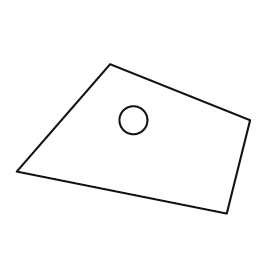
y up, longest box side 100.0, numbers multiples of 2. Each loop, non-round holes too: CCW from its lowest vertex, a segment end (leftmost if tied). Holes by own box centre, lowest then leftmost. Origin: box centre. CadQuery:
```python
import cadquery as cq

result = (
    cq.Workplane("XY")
    .moveTo(40.0, -32.0)
    .lineTo(50.0, 8.0)
    .lineTo(-10.0, 32.0)
    .lineTo(-50.0, -14.0)
    .close()
    .moveTo(0.0, 8.0)
    .circle(6.0)
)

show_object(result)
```